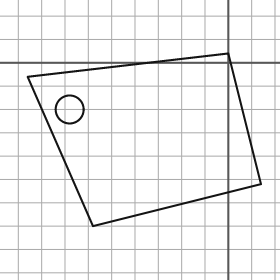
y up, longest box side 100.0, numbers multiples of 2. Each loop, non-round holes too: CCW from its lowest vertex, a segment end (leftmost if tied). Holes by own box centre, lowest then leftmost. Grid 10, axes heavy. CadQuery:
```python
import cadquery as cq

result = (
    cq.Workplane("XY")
    .moveTo(-58.0, -70.0)
    .lineTo(14.0, -52.0)
    .lineTo(0.0, 4.0)
    .lineTo(-86.0, -6.0)
    .close()
    .moveTo(-68.0, -20.0)
    .circle(6.0)
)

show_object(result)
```